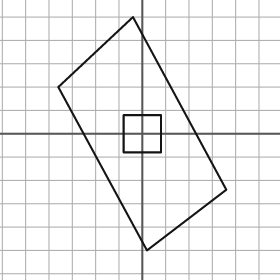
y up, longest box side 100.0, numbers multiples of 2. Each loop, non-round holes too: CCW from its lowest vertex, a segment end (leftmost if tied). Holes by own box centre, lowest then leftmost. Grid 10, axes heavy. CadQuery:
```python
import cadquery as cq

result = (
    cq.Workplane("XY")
    .moveTo(2.0, -50.0)
    .lineTo(36.0, -24.0)
    .lineTo(-4.0, 50.0)
    .lineTo(-36.0, 20.0)
    .close()
    .moveTo(-8.0, -8.0)
    .lineTo(8.0, -8.0)
    .lineTo(8.0, 8.0)
    .lineTo(-8.0, 8.0)
    .close()
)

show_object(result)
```